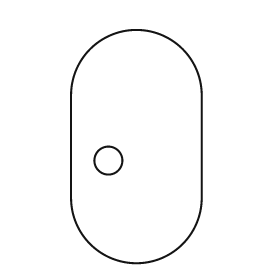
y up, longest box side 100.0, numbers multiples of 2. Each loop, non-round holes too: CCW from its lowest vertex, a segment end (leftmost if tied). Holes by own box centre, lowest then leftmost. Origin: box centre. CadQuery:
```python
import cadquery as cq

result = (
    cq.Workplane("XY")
    .moveTo(-28.0, -22.0)
    .threePointArc((0.0, -50.0), (28.0, -22.0))
    .lineTo(28.0, 22.0)
    .threePointArc((0.0, 50.0), (-28.0, 22.0))
    .close()
    .moveTo(-12.0, -6.0)
    .circle(6.0)
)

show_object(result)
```